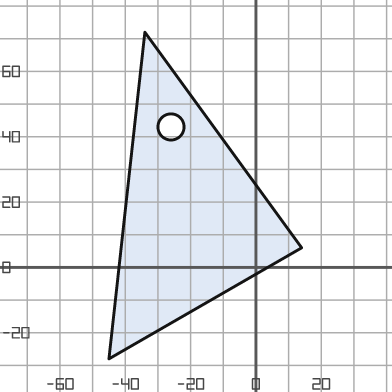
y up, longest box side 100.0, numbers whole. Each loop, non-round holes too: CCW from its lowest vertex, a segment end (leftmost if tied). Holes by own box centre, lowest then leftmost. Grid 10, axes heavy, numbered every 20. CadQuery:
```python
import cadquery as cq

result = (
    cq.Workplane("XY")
    .moveTo(-45.0, -28.0)
    .lineTo(14.0, 6.0)
    .lineTo(-34.0, 72.0)
    .close()
    .moveTo(-26.0, 43.0)
    .circle(4.0)
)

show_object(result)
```